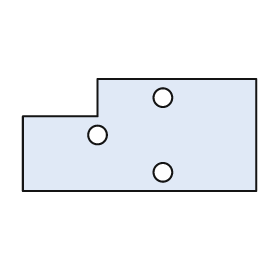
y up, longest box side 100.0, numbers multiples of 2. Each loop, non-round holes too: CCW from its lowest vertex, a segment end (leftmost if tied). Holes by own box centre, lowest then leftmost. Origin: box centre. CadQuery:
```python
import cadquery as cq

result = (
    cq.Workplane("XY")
    .moveTo(-50.0, -24.0)
    .lineTo(50.0, -24.0)
    .lineTo(50.0, 24.0)
    .lineTo(-18.0, 24.0)
    .lineTo(-18.0, 8.0)
    .lineTo(-50.0, 8.0)
    .close()
    .moveTo(10.0, -16.0)
    .circle(4.0)
    .moveTo(-18.0, 0.0)
    .circle(4.0)
    .moveTo(10.0, 16.0)
    .circle(4.0)
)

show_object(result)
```